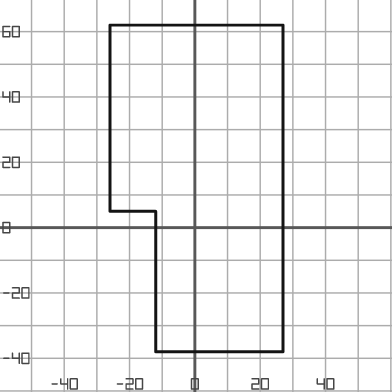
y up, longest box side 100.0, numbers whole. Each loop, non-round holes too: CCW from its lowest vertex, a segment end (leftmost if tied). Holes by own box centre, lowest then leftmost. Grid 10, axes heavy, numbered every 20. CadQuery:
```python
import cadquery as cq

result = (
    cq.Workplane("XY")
    .moveTo(-12.0, -38.0)
    .lineTo(27.0, -38.0)
    .lineTo(27.0, 62.0)
    .lineTo(-26.0, 62.0)
    .lineTo(-26.0, 5.0)
    .lineTo(-12.0, 5.0)
    .close()
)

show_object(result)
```